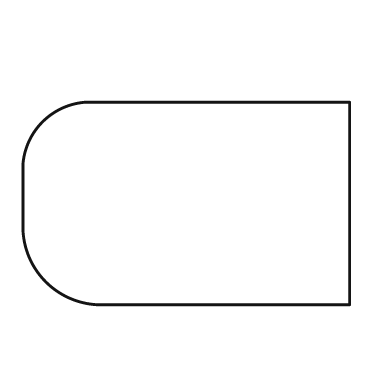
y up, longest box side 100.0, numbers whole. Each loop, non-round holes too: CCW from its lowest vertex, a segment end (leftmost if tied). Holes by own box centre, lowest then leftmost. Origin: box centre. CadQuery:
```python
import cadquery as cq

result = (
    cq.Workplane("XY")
    .moveTo(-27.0, -31.0)
    .lineTo(50.0, -31.0)
    .lineTo(50.0, 31.0)
    .lineTo(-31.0, 31.0)
    .threePointArc((-44.0, 25.0), (-50.0, 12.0))
    .lineTo(-50.0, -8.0)
    .threePointArc((-43.0, -24.0), (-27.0, -31.0))
    .close()
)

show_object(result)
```